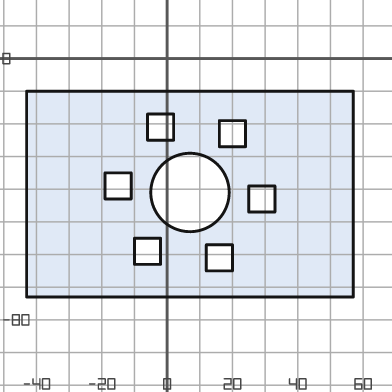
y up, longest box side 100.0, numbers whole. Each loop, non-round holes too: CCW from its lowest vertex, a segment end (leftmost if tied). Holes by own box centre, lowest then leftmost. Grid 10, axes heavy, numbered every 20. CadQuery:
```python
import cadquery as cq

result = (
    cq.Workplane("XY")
    .moveTo(-43.0, -73.0)
    .lineTo(57.0, -73.0)
    .lineTo(57.0, -10.0)
    .lineTo(-43.0, -10.0)
    .close()
    .moveTo(12.0, -65.0)
    .lineTo(20.0, -65.0)
    .lineTo(20.0, -57.0)
    .lineTo(12.0, -57.0)
    .close()
    .moveTo(-10.0, -63.0)
    .lineTo(-2.0, -63.0)
    .lineTo(-2.0, -55.0)
    .lineTo(-10.0, -55.0)
    .close()
    .moveTo(25.0, -47.0)
    .lineTo(33.0, -47.0)
    .lineTo(33.0, -39.0)
    .lineTo(25.0, -39.0)
    .close()
    .moveTo(7.0, -41.0)
    .circle(12.0)
    .moveTo(-19.0, -43.0)
    .lineTo(-11.0, -43.0)
    .lineTo(-11.0, -35.0)
    .lineTo(-19.0, -35.0)
    .close()
    .moveTo(16.0, -27.0)
    .lineTo(24.0, -27.0)
    .lineTo(24.0, -19.0)
    .lineTo(16.0, -19.0)
    .close()
    .moveTo(-6.0, -25.0)
    .lineTo(2.0, -25.0)
    .lineTo(2.0, -17.0)
    .lineTo(-6.0, -17.0)
    .close()
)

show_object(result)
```